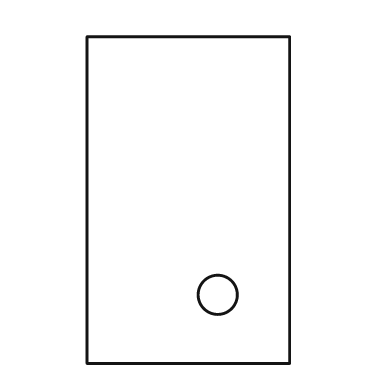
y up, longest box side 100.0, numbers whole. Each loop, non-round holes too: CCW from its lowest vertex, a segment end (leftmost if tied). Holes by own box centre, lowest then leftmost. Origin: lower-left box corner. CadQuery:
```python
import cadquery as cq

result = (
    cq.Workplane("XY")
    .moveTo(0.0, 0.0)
    .lineTo(62.0, 0.0)
    .lineTo(62.0, 100.0)
    .lineTo(0.0, 100.0)
    .close()
    .moveTo(40.0, 21.0)
    .circle(6.0)
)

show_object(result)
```